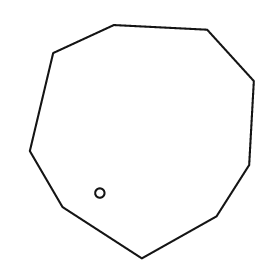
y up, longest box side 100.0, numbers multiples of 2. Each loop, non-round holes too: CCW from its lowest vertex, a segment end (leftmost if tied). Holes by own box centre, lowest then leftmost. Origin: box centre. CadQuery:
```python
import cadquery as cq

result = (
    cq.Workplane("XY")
    .moveTo(0.0, -50.0)
    .lineTo(32.0, -32.0)
    .lineTo(46.0, -10.0)
    .lineTo(48.0, 26.0)
    .lineTo(28.0, 48.0)
    .lineTo(-12.0, 50.0)
    .lineTo(-38.0, 38.0)
    .lineTo(-48.0, -4.0)
    .lineTo(-34.0, -28.0)
    .close()
    .moveTo(-18.0, -22.0)
    .circle(2.0)
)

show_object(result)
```